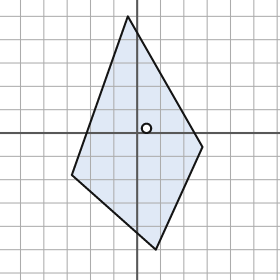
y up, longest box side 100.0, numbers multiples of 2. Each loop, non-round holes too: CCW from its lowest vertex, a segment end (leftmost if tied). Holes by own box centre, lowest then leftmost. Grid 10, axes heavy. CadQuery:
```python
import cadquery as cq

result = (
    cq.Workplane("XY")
    .moveTo(8.0, -50.0)
    .lineTo(28.0, -6.0)
    .lineTo(-4.0, 50.0)
    .lineTo(-28.0, -18.0)
    .close()
    .moveTo(4.0, 2.0)
    .circle(2.0)
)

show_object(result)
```